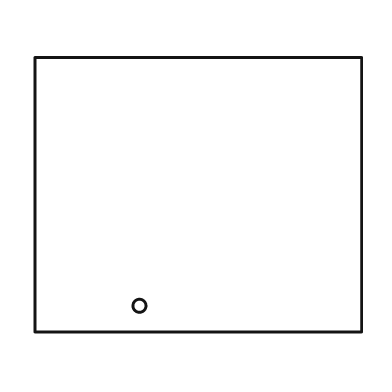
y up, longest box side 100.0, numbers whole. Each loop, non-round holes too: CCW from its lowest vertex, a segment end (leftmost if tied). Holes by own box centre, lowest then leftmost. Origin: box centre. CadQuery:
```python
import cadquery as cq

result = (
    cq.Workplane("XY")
    .moveTo(-50.0, -42.0)
    .lineTo(50.0, -42.0)
    .lineTo(50.0, 42.0)
    .lineTo(-50.0, 42.0)
    .close()
    .moveTo(-18.0, -34.0)
    .circle(2.0)
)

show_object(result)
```